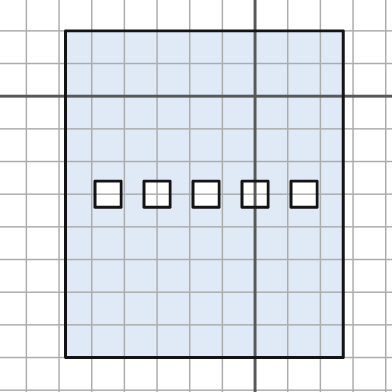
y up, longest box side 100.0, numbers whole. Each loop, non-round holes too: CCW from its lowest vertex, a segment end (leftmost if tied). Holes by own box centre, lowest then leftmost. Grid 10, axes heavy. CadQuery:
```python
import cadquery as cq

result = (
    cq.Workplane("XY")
    .moveTo(-58.0, -80.0)
    .lineTo(27.0, -80.0)
    .lineTo(27.0, 20.0)
    .lineTo(-58.0, 20.0)
    .close()
    .moveTo(-49.0, -34.0)
    .lineTo(-41.0, -34.0)
    .lineTo(-41.0, -26.0)
    .lineTo(-49.0, -26.0)
    .close()
    .moveTo(-34.0, -34.0)
    .lineTo(-26.0, -34.0)
    .lineTo(-26.0, -26.0)
    .lineTo(-34.0, -26.0)
    .close()
    .moveTo(-19.0, -34.0)
    .lineTo(-11.0, -34.0)
    .lineTo(-11.0, -26.0)
    .lineTo(-19.0, -26.0)
    .close()
    .moveTo(-4.0, -34.0)
    .lineTo(4.0, -34.0)
    .lineTo(4.0, -26.0)
    .lineTo(-4.0, -26.0)
    .close()
    .moveTo(11.0, -34.0)
    .lineTo(19.0, -34.0)
    .lineTo(19.0, -26.0)
    .lineTo(11.0, -26.0)
    .close()
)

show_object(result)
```